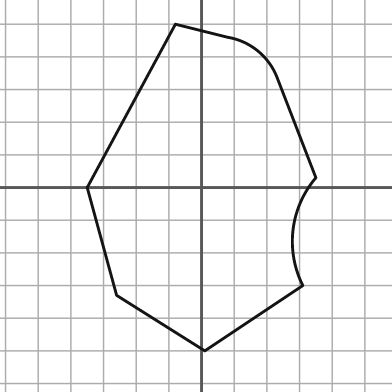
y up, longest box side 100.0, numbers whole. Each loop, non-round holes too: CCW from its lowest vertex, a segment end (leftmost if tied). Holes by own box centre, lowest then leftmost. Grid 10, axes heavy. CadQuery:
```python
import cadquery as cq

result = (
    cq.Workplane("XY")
    .moveTo(1.0, -50.0)
    .lineTo(31.0, -30.0)
    .threePointArc((28.0, -13.0), (35.0, 3.0))
    .lineTo(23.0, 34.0)
    .threePointArc((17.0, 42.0), (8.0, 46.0))
    .lineTo(-8.0, 50.0)
    .lineTo(-35.0, 0.0)
    .lineTo(-26.0, -33.0)
    .close()
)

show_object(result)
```